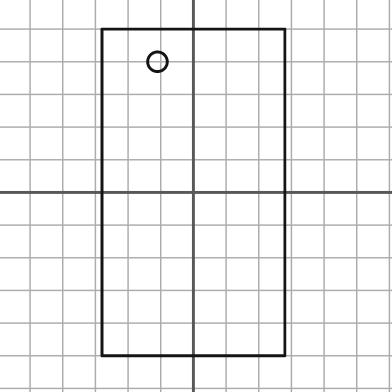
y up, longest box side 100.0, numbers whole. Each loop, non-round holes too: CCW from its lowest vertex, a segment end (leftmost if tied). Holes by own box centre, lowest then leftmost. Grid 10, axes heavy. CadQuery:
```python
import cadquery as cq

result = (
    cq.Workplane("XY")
    .moveTo(-28.0, -50.0)
    .lineTo(28.0, -50.0)
    .lineTo(28.0, 50.0)
    .lineTo(-28.0, 50.0)
    .close()
    .moveTo(-11.0, 40.0)
    .circle(3.0)
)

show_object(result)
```